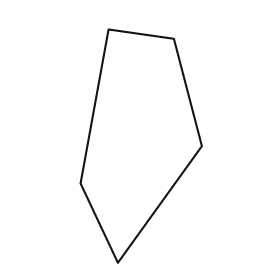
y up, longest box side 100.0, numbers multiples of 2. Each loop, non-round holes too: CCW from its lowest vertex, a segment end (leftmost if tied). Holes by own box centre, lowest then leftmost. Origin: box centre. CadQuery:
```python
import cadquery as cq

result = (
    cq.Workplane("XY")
    .moveTo(-10.0, -50.0)
    .lineTo(26.0, 0.0)
    .lineTo(14.0, 46.0)
    .lineTo(-14.0, 50.0)
    .lineTo(-26.0, -16.0)
    .close()
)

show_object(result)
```